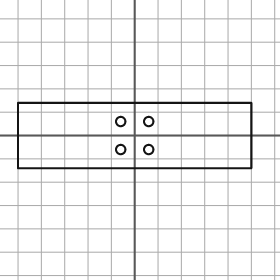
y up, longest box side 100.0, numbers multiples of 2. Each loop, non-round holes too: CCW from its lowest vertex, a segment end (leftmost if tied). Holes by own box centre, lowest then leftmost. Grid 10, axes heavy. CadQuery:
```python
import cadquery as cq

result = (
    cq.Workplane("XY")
    .moveTo(-50.0, -14.0)
    .lineTo(50.0, -14.0)
    .lineTo(50.0, 14.0)
    .lineTo(-50.0, 14.0)
    .close()
    .moveTo(-6.0, -6.0)
    .circle(2.0)
    .moveTo(6.0, -6.0)
    .circle(2.0)
    .moveTo(-6.0, 6.0)
    .circle(2.0)
    .moveTo(6.0, 6.0)
    .circle(2.0)
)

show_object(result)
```